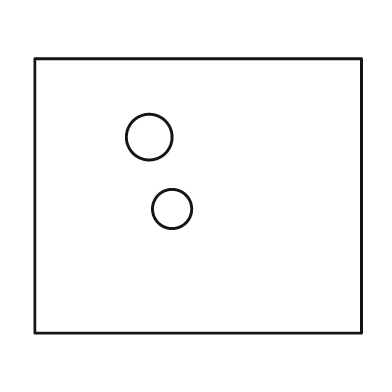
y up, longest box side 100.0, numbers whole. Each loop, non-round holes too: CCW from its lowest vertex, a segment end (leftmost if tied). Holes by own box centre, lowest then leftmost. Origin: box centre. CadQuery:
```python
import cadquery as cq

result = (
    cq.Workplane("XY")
    .moveTo(-50.0, -42.0)
    .lineTo(50.0, -42.0)
    .lineTo(50.0, 42.0)
    .lineTo(-50.0, 42.0)
    .close()
    .moveTo(-8.0, -4.0)
    .circle(6.0)
    .moveTo(-15.0, 18.0)
    .circle(7.0)
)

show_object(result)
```